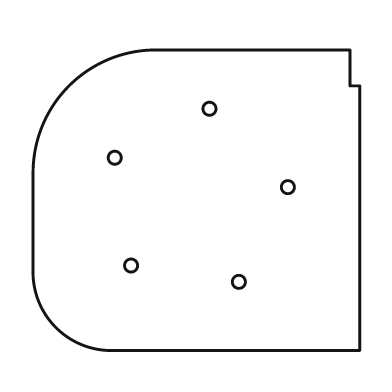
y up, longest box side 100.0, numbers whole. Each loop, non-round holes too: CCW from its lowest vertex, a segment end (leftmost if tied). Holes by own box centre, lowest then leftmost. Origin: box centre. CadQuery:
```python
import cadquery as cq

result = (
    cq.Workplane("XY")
    .moveTo(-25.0, -46.0)
    .lineTo(50.0, -46.0)
    .lineTo(50.0, 35.0)
    .lineTo(47.0, 35.0)
    .lineTo(47.0, 46.0)
    .lineTo(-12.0, 46.0)
    .threePointArc((-39.0, 35.0), (-50.0, 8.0))
    .lineTo(-50.0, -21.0)
    .threePointArc((-43.0, -39.0), (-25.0, -46.0))
    .close()
    .moveTo(13.0, -25.0)
    .circle(2.0)
    .moveTo(-20.0, -20.0)
    .circle(2.0)
    .moveTo(28.0, 4.0)
    .circle(2.0)
    .moveTo(-25.0, 13.0)
    .circle(2.0)
    .moveTo(4.0, 28.0)
    .circle(2.0)
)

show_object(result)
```